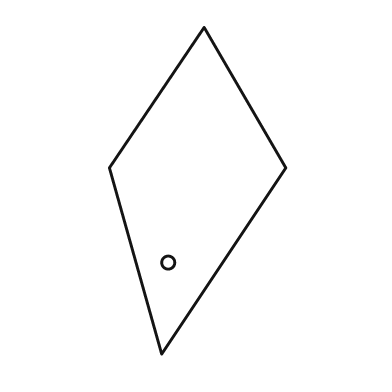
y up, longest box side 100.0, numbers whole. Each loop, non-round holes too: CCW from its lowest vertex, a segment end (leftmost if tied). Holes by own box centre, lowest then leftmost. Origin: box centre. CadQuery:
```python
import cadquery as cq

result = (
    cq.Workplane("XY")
    .moveTo(-11.0, -50.0)
    .lineTo(27.0, 7.0)
    .lineTo(2.0, 50.0)
    .lineTo(-27.0, 7.0)
    .close()
    .moveTo(-9.0, -22.0)
    .circle(2.0)
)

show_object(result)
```